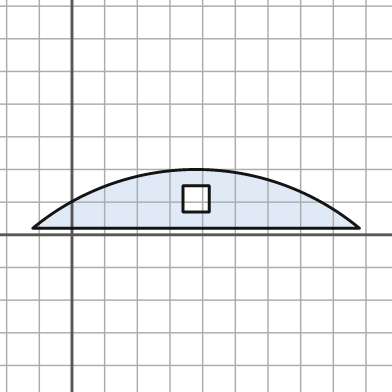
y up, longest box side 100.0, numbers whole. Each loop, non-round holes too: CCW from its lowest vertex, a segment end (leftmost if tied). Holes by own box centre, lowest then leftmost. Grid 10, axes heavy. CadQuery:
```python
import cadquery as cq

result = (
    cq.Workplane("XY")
    .moveTo(-12.0, 2.0)
    .lineTo(88.0, 2.0)
    .threePointArc((38.0, 20.0), (-12.0, 2.0))
    .close()
    .moveTo(34.0, 7.0)
    .lineTo(42.0, 7.0)
    .lineTo(42.0, 15.0)
    .lineTo(34.0, 15.0)
    .close()
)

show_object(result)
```